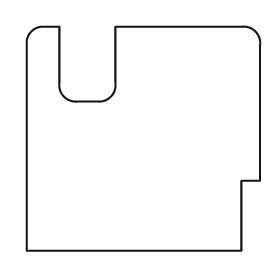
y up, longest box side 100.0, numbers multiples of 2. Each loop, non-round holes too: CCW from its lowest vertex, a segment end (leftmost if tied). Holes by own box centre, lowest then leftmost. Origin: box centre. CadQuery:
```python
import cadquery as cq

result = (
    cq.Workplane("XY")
    .moveTo(-50.0, -48.0)
    .lineTo(42.0, -48.0)
    .lineTo(42.0, -18.0)
    .lineTo(50.0, -18.0)
    .lineTo(50.0, 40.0)
    .threePointArc((48.0, 46.0), (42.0, 48.0))
    .lineTo(-12.0, 48.0)
    .lineTo(-12.0, 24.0)
    .threePointArc((-14.0, 18.0), (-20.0, 16.0))
    .lineTo(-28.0, 16.0)
    .threePointArc((-34.0, 18.0), (-36.0, 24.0))
    .lineTo(-36.0, 48.0)
    .lineTo(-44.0, 48.0)
    .threePointArc((-48.0, 46.0), (-50.0, 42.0))
    .close()
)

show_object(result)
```